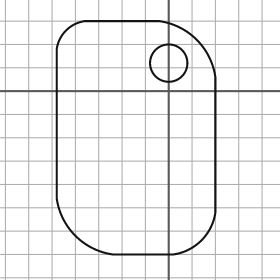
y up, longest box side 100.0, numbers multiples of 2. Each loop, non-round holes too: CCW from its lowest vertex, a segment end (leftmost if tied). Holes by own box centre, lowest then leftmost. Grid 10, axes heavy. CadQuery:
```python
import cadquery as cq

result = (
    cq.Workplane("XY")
    .moveTo(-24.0, -70.0)
    .lineTo(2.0, -70.0)
    .threePointArc((14.0, -64.0), (20.0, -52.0))
    .lineTo(20.0, 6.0)
    .threePointArc((12.0, 22.0), (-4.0, 30.0))
    .lineTo(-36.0, 30.0)
    .threePointArc((-44.0, 26.0), (-48.0, 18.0))
    .lineTo(-48.0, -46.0)
    .threePointArc((-40.0, -62.0), (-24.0, -70.0))
    .close()
    .moveTo(0.0, 12.0)
    .circle(8.0)
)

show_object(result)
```